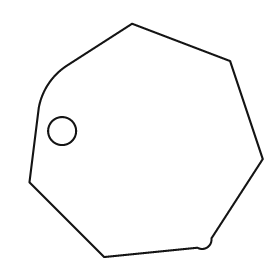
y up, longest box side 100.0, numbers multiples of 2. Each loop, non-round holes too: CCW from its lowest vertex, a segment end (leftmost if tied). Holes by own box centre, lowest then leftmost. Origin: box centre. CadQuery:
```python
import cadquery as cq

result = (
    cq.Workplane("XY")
    .moveTo(-18.0, -50.0)
    .lineTo(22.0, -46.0)
    .threePointArc((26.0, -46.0), (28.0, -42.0))
    .lineTo(50.0, -8.0)
    .lineTo(36.0, 34.0)
    .lineTo(-6.0, 50.0)
    .lineTo(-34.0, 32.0)
    .threePointArc((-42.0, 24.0), (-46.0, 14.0))
    .lineTo(-50.0, -18.0)
    .close()
    .moveTo(-36.0, 4.0)
    .circle(6.0)
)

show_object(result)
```